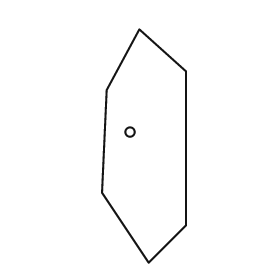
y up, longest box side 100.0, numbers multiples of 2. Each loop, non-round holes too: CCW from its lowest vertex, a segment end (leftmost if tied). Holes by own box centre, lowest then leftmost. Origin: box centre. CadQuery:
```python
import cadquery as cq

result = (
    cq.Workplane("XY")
    .moveTo(2.0, -50.0)
    .lineTo(18.0, -34.0)
    .lineTo(18.0, 32.0)
    .lineTo(-2.0, 50.0)
    .lineTo(-16.0, 24.0)
    .lineTo(-18.0, -20.0)
    .close()
    .moveTo(-6.0, 6.0)
    .circle(2.0)
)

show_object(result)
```